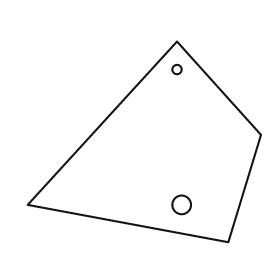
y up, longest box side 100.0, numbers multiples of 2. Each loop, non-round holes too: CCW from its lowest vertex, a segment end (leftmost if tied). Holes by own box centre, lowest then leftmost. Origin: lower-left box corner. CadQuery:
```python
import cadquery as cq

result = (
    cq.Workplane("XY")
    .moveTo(86.0, 0.0)
    .lineTo(100.0, 46.0)
    .lineTo(64.0, 86.0)
    .lineTo(0.0, 16.0)
    .close()
    .moveTo(66.0, 16.0)
    .circle(4.0)
    .moveTo(64.0, 74.0)
    .circle(2.0)
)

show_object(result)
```